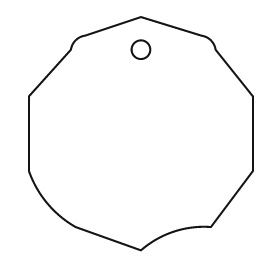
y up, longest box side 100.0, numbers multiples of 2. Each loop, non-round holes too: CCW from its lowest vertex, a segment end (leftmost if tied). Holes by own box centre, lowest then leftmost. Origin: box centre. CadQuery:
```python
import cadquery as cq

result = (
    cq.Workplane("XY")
    .moveTo(0.0, -50.0)
    .threePointArc((14.0, -42.0), (30.0, -40.0))
    .lineTo(48.0, -16.0)
    .lineTo(48.0, 16.0)
    .lineTo(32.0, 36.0)
    .threePointArc((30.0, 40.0), (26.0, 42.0))
    .lineTo(0.0, 50.0)
    .lineTo(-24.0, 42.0)
    .threePointArc((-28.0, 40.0), (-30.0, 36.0))
    .lineTo(-48.0, 16.0)
    .lineTo(-48.0, -16.0)
    .threePointArc((-40.0, -30.0), (-28.0, -40.0))
    .close()
    .moveTo(0.0, 36.0)
    .circle(4.0)
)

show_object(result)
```